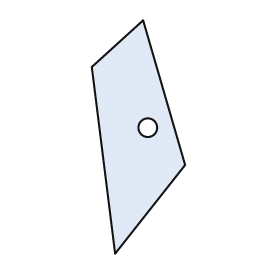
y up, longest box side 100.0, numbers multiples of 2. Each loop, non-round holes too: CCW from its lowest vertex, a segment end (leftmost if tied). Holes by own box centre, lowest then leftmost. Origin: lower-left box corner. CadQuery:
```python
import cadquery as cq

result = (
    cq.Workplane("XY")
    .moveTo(10.0, 0.0)
    .lineTo(40.0, 38.0)
    .lineTo(22.0, 100.0)
    .lineTo(0.0, 80.0)
    .close()
    .moveTo(24.0, 54.0)
    .circle(4.0)
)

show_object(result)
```